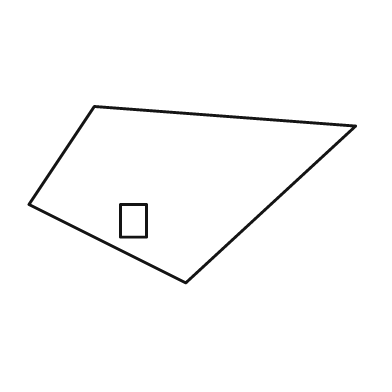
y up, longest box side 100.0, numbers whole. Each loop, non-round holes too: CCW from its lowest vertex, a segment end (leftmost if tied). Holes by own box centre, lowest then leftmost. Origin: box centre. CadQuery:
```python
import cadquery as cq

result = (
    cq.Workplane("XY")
    .moveTo(-2.0, -27.0)
    .lineTo(50.0, 21.0)
    .lineTo(-30.0, 27.0)
    .lineTo(-50.0, -3.0)
    .close()
    .moveTo(-22.0, -13.0)
    .lineTo(-14.0, -13.0)
    .lineTo(-14.0, -3.0)
    .lineTo(-22.0, -3.0)
    .close()
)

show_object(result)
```